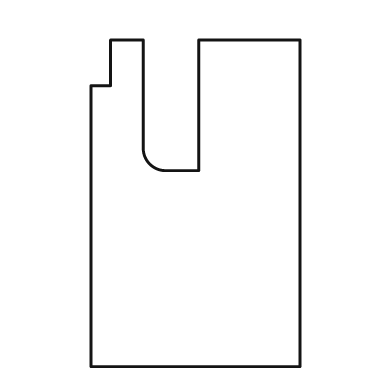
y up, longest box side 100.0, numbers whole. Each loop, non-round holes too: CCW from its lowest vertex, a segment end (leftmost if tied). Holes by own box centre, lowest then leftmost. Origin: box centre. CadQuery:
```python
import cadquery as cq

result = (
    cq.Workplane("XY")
    .moveTo(-32.0, -50.0)
    .lineTo(32.0, -50.0)
    .lineTo(32.0, 50.0)
    .lineTo(1.0, 50.0)
    .lineTo(1.0, 10.0)
    .lineTo(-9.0, 10.0)
    .threePointArc((-14.0, 12.0), (-16.0, 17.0))
    .lineTo(-16.0, 50.0)
    .lineTo(-26.0, 50.0)
    .lineTo(-26.0, 36.0)
    .lineTo(-32.0, 36.0)
    .close()
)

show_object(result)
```